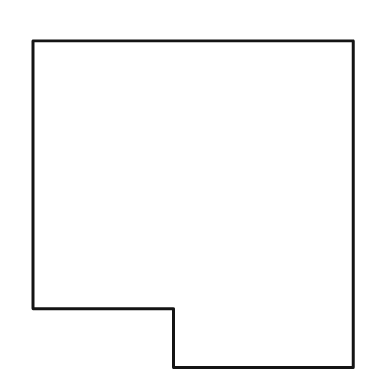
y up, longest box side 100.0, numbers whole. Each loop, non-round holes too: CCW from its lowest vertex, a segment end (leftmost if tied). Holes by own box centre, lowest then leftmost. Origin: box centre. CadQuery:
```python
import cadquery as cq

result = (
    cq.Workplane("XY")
    .moveTo(-6.0, -50.0)
    .lineTo(49.0, -50.0)
    .lineTo(49.0, 50.0)
    .lineTo(-49.0, 50.0)
    .lineTo(-49.0, -32.0)
    .lineTo(-6.0, -32.0)
    .close()
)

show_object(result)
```